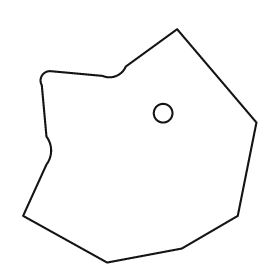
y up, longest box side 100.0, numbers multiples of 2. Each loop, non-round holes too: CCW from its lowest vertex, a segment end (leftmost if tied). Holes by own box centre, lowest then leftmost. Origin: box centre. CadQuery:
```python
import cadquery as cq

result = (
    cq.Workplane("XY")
    .moveTo(-14.0, -50.0)
    .lineTo(18.0, -44.0)
    .lineTo(42.0, -30.0)
    .lineTo(50.0, 10.0)
    .lineTo(16.0, 50.0)
    .lineTo(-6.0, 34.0)
    .threePointArc((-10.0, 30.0), (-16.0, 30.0))
    .lineTo(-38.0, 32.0)
    .threePointArc((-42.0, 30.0), (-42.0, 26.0))
    .lineTo(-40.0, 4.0)
    .threePointArc((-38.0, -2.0), (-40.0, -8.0))
    .lineTo(-50.0, -30.0)
    .close()
    .moveTo(10.0, 14.0)
    .circle(4.0)
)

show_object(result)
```